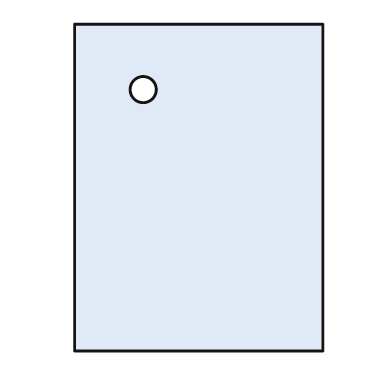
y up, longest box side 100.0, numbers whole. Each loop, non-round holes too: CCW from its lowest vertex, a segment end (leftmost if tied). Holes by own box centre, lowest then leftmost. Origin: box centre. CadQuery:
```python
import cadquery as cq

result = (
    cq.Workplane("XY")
    .moveTo(-38.0, -50.0)
    .lineTo(38.0, -50.0)
    .lineTo(38.0, 50.0)
    .lineTo(-38.0, 50.0)
    .close()
    .moveTo(-17.0, 30.0)
    .circle(4.0)
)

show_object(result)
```